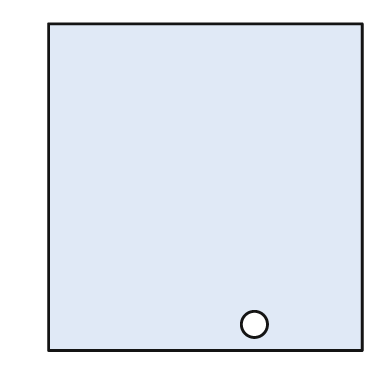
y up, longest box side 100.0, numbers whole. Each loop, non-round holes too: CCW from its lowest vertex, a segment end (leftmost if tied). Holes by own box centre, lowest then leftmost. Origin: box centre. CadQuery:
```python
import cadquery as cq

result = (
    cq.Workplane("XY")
    .moveTo(-48.0, -50.0)
    .lineTo(48.0, -50.0)
    .lineTo(48.0, 50.0)
    .lineTo(-48.0, 50.0)
    .close()
    .moveTo(15.0, -42.0)
    .circle(4.0)
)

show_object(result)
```